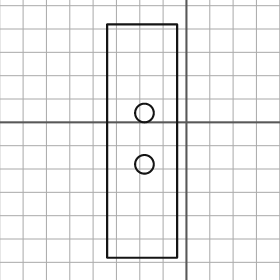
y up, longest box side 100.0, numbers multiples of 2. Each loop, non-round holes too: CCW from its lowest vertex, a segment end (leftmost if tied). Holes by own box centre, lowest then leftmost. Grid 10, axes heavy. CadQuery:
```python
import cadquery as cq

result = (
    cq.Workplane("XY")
    .moveTo(-34.0, -58.0)
    .lineTo(-4.0, -58.0)
    .lineTo(-4.0, 42.0)
    .lineTo(-34.0, 42.0)
    .close()
    .moveTo(-18.0, -18.0)
    .circle(4.0)
    .moveTo(-18.0, 4.0)
    .circle(4.0)
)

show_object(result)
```